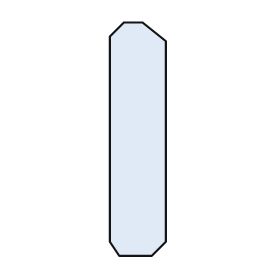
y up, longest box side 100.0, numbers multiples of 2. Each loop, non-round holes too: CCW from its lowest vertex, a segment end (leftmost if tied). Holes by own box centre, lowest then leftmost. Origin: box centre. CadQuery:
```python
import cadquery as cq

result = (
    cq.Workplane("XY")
    .moveTo(-8.0, -50.0)
    .lineTo(6.0, -50.0)
    .lineTo(12.0, -44.0)
    .lineTo(12.0, 42.0)
    .lineTo(2.0, 50.0)
    .lineTo(-6.0, 50.0)
    .lineTo(-12.0, 44.0)
    .lineTo(-12.0, -44.0)
    .close()
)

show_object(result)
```